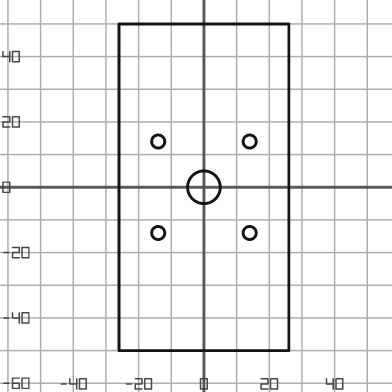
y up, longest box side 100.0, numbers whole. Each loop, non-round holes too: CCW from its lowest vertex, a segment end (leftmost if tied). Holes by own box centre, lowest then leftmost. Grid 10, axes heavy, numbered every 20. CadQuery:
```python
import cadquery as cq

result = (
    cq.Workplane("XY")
    .moveTo(-26.0, -50.0)
    .lineTo(26.0, -50.0)
    .lineTo(26.0, 50.0)
    .lineTo(-26.0, 50.0)
    .close()
    .moveTo(-14.0, -14.0)
    .circle(2.0)
    .moveTo(14.0, -14.0)
    .circle(2.0)
    .moveTo(0.0, 0.0)
    .circle(5.0)
    .moveTo(-14.0, 14.0)
    .circle(2.0)
    .moveTo(14.0, 14.0)
    .circle(2.0)
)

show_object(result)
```